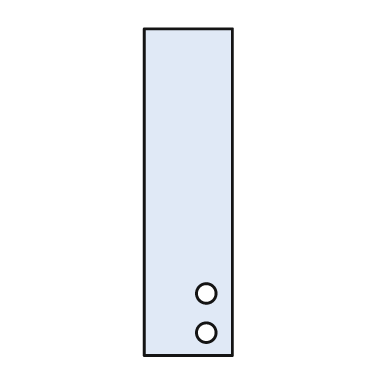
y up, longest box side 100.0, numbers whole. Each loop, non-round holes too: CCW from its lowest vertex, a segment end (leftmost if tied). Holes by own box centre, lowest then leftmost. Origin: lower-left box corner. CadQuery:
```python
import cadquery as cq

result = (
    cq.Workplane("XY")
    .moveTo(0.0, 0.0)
    .lineTo(27.0, 0.0)
    .lineTo(27.0, 100.0)
    .lineTo(0.0, 100.0)
    .close()
    .moveTo(19.0, 7.0)
    .circle(3.0)
    .moveTo(19.0, 19.0)
    .circle(3.0)
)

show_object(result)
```